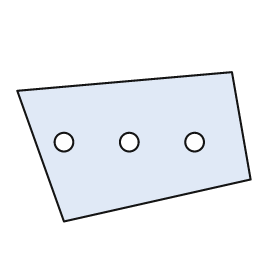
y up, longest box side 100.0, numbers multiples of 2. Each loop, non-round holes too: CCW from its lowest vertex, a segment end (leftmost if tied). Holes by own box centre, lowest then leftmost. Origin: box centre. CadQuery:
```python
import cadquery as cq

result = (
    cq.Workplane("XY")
    .moveTo(-30.0, -32.0)
    .lineTo(50.0, -14.0)
    .lineTo(42.0, 32.0)
    .lineTo(-50.0, 24.0)
    .close()
    .moveTo(-30.0, 2.0)
    .circle(4.0)
    .moveTo(-2.0, 2.0)
    .circle(4.0)
    .moveTo(26.0, 2.0)
    .circle(4.0)
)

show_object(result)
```